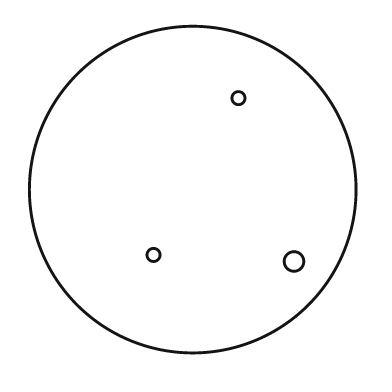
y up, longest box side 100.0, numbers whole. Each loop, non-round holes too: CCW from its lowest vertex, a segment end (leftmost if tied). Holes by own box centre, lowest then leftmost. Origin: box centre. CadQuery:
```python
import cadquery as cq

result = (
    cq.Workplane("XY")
    .moveTo(0.0, 0.0)
    .circle(50.0)
    .moveTo(31.0, -22.0)
    .circle(3.0)
    .moveTo(-12.0, -20.0)
    .circle(2.0)
    .moveTo(14.0, 28.0)
    .circle(2.0)
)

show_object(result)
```